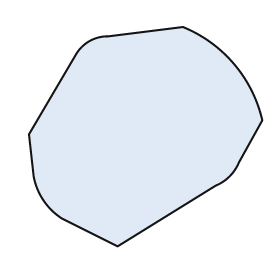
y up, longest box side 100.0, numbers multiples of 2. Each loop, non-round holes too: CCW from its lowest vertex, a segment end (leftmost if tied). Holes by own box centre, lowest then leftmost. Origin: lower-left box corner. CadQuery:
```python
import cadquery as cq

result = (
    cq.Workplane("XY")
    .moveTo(38.0, 0.0)
    .lineTo(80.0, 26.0)
    .threePointArc((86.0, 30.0), (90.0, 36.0))
    .lineTo(100.0, 54.0)
    .threePointArc((88.0, 78.0), (66.0, 94.0))
    .lineTo(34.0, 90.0)
    .threePointArc((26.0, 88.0), (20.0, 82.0))
    .lineTo(0.0, 48.0)
    .lineTo(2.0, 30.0)
    .threePointArc((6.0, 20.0), (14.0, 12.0))
    .close()
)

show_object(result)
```